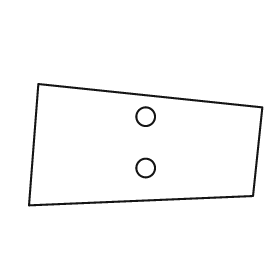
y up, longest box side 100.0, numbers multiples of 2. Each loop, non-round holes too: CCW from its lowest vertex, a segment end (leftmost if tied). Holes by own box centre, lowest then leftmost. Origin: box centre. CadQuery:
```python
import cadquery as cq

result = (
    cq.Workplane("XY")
    .moveTo(-50.0, -26.0)
    .lineTo(46.0, -22.0)
    .lineTo(50.0, 16.0)
    .lineTo(-46.0, 26.0)
    .close()
    .moveTo(0.0, -10.0)
    .circle(4.0)
    .moveTo(0.0, 12.0)
    .circle(4.0)
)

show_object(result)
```